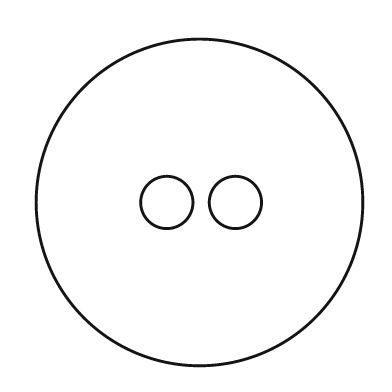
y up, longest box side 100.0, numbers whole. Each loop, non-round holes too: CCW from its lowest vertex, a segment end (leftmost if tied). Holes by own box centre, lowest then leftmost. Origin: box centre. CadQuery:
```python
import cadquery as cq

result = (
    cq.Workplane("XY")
    .moveTo(0.0, 0.0)
    .circle(50.0)
    .moveTo(-10.0, 0.0)
    .circle(8.0)
    .moveTo(11.0, 0.0)
    .circle(8.0)
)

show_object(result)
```